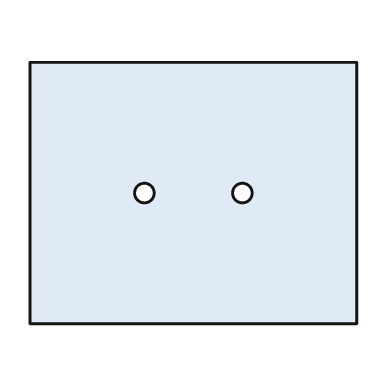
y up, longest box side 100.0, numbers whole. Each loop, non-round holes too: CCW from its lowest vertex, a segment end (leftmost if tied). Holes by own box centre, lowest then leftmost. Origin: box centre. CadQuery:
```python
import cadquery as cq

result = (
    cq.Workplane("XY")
    .moveTo(-50.0, -40.0)
    .lineTo(50.0, -40.0)
    .lineTo(50.0, 40.0)
    .lineTo(-50.0, 40.0)
    .close()
    .moveTo(-15.0, 0.0)
    .circle(3.0)
    .moveTo(15.0, 0.0)
    .circle(3.0)
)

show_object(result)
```